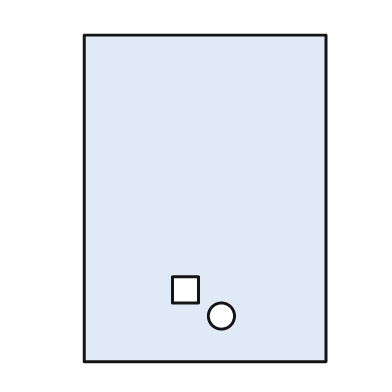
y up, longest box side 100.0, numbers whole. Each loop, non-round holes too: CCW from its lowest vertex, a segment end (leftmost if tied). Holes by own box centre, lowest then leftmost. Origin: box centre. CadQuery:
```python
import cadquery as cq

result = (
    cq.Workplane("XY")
    .moveTo(-37.0, -50.0)
    .lineTo(37.0, -50.0)
    .lineTo(37.0, 50.0)
    .lineTo(-37.0, 50.0)
    .close()
    .moveTo(5.0, -36.0)
    .circle(4.0)
    .moveTo(-10.0, -32.0)
    .lineTo(-2.0, -32.0)
    .lineTo(-2.0, -24.0)
    .lineTo(-10.0, -24.0)
    .close()
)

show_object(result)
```